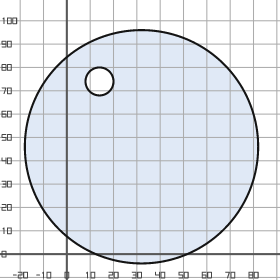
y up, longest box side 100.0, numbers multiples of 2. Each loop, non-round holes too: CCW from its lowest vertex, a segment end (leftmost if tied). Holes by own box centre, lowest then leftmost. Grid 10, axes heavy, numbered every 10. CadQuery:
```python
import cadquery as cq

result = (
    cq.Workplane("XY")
    .moveTo(32.0, 46.0)
    .circle(50.0)
    .moveTo(14.0, 74.0)
    .circle(6.0)
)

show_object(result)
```